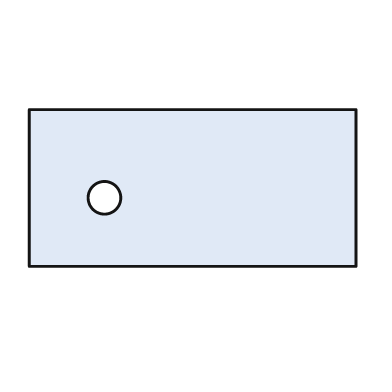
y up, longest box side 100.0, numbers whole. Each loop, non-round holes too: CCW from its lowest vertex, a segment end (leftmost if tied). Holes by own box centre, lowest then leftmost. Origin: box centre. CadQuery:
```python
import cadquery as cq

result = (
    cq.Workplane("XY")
    .moveTo(-50.0, -24.0)
    .lineTo(50.0, -24.0)
    .lineTo(50.0, 24.0)
    .lineTo(-50.0, 24.0)
    .close()
    .moveTo(-27.0, -3.0)
    .circle(5.0)
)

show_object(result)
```